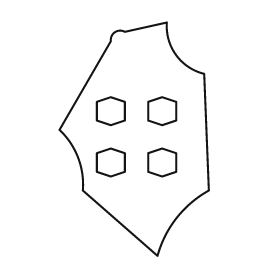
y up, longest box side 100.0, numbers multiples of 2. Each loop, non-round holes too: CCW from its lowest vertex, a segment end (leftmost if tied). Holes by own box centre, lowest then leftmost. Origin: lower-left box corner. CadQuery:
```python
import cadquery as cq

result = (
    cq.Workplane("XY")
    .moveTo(42.0, 0.0)
    .threePointArc((50.0, 16.0), (64.0, 28.0))
    .lineTo(62.0, 78.0)
    .threePointArc((50.0, 86.0), (46.0, 100.0))
    .lineTo(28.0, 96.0)
    .threePointArc((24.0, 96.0), (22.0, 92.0))
    .lineTo(0.0, 54.0)
    .threePointArc((8.0, 42.0), (10.0, 28.0))
    .close()
    .moveTo(22.0, 34.0)
    .lineTo(28.0, 36.0)
    .lineTo(28.0, 44.0)
    .lineTo(22.0, 46.0)
    .lineTo(16.0, 44.0)
    .lineTo(16.0, 36.0)
    .close()
    .moveTo(44.0, 34.0)
    .lineTo(50.0, 36.0)
    .lineTo(50.0, 44.0)
    .lineTo(44.0, 46.0)
    .lineTo(38.0, 44.0)
    .lineTo(38.0, 36.0)
    .close()
    .moveTo(22.0, 56.0)
    .lineTo(28.0, 58.0)
    .lineTo(28.0, 66.0)
    .lineTo(22.0, 68.0)
    .lineTo(16.0, 66.0)
    .lineTo(16.0, 58.0)
    .close()
    .moveTo(44.0, 56.0)
    .lineTo(50.0, 58.0)
    .lineTo(50.0, 66.0)
    .lineTo(44.0, 68.0)
    .lineTo(38.0, 66.0)
    .lineTo(38.0, 58.0)
    .close()
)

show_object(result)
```